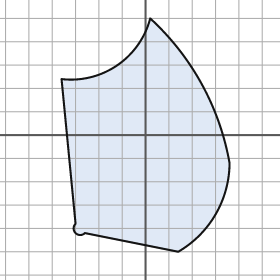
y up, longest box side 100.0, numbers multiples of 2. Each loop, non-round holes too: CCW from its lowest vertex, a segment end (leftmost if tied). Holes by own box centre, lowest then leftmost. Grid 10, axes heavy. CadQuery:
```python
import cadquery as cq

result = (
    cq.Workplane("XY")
    .moveTo(14.0, -50.0)
    .threePointArc((30.0, -34.0), (36.0, -12.0))
    .threePointArc((24.0, 22.0), (2.0, 50.0))
    .threePointArc((-12.0, 30.0), (-36.0, 24.0))
    .lineTo(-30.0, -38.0)
    .threePointArc((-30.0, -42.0), (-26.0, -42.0))
    .close()
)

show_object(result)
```